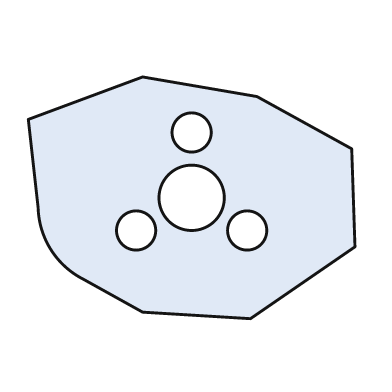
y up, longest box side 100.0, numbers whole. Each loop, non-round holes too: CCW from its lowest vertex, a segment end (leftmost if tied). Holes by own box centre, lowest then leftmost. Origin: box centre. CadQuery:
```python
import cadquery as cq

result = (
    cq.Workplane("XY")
    .moveTo(18.0, -37.0)
    .lineTo(50.0, -15.0)
    .lineTo(49.0, 15.0)
    .lineTo(20.0, 31.0)
    .lineTo(-15.0, 37.0)
    .lineTo(-50.0, 24.0)
    .lineTo(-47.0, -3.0)
    .threePointArc((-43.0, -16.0), (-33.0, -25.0))
    .lineTo(-15.0, -35.0)
    .close()
    .moveTo(-17.0, -10.0)
    .circle(6.0)
    .moveTo(17.0, -10.0)
    .circle(6.0)
    .moveTo(0.0, 0.0)
    .circle(10.0)
    .moveTo(0.0, 20.0)
    .circle(6.0)
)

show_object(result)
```